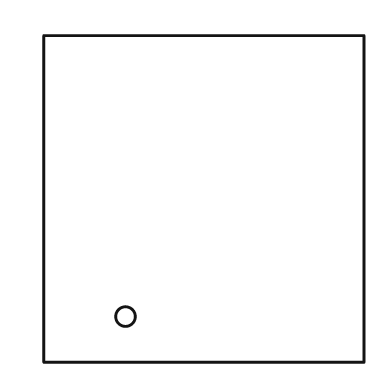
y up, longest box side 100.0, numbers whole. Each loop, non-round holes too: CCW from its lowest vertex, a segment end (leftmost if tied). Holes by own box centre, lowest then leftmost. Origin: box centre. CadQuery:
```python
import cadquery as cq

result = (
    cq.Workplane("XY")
    .moveTo(-49.0, -50.0)
    .lineTo(49.0, -50.0)
    .lineTo(49.0, 50.0)
    .lineTo(-49.0, 50.0)
    .close()
    .moveTo(-24.0, -36.0)
    .circle(3.0)
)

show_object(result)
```